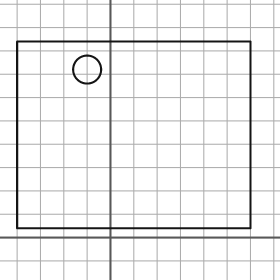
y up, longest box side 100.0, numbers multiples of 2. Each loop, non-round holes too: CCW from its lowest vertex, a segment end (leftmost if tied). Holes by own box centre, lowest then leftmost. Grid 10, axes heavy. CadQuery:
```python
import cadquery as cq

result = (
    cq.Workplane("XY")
    .moveTo(-40.0, 4.0)
    .lineTo(60.0, 4.0)
    .lineTo(60.0, 84.0)
    .lineTo(-40.0, 84.0)
    .close()
    .moveTo(-10.0, 72.0)
    .circle(6.0)
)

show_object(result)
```